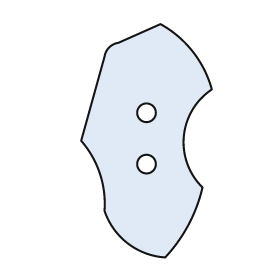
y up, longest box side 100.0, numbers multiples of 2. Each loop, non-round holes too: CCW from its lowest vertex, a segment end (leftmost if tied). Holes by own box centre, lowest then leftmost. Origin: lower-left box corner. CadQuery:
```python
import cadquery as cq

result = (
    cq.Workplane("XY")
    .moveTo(36.0, 0.0)
    .threePointArc((46.0, 14.0), (52.0, 30.0))
    .threePointArc((44.0, 52.0), (56.0, 72.0))
    .threePointArc((48.0, 88.0), (34.0, 100.0))
    .lineTo(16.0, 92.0)
    .threePointArc((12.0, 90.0), (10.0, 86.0))
    .lineTo(0.0, 50.0)
    .threePointArc((8.0, 36.0), (10.0, 20.0))
    .threePointArc((20.0, 6.0), (36.0, 0.0))
    .close()
    .moveTo(28.0, 40.0)
    .circle(4.0)
    .moveTo(28.0, 62.0)
    .circle(4.0)
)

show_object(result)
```